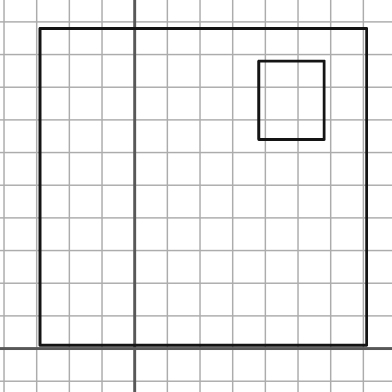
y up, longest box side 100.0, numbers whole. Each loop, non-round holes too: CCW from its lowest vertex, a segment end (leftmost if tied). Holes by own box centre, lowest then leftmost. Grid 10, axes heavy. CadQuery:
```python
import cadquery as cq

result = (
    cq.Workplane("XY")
    .moveTo(-29.0, 1.0)
    .lineTo(71.0, 1.0)
    .lineTo(71.0, 98.0)
    .lineTo(-29.0, 98.0)
    .close()
    .moveTo(38.0, 64.0)
    .lineTo(58.0, 64.0)
    .lineTo(58.0, 88.0)
    .lineTo(38.0, 88.0)
    .close()
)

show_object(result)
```